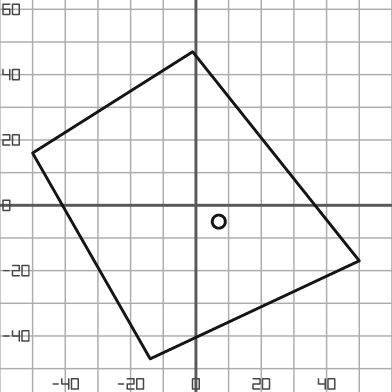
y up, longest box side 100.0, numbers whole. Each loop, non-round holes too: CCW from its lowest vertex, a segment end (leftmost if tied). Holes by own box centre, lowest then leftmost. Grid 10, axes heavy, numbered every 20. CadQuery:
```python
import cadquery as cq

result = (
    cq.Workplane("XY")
    .moveTo(-14.0, -47.0)
    .lineTo(50.0, -17.0)
    .lineTo(-1.0, 47.0)
    .lineTo(-50.0, 16.0)
    .close()
    .moveTo(7.0, -5.0)
    .circle(2.0)
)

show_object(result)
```